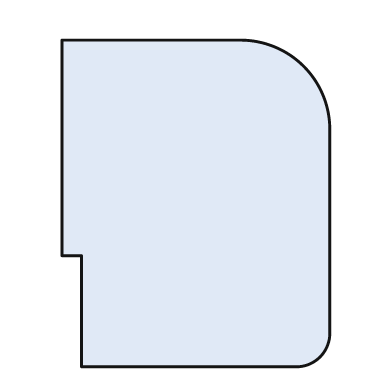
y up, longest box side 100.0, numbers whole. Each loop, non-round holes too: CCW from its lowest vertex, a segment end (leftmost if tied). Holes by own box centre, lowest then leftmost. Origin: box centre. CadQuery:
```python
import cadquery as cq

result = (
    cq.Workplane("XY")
    .moveTo(-35.0, -50.0)
    .lineTo(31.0, -50.0)
    .threePointArc((38.0, -47.0), (41.0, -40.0))
    .lineTo(41.0, 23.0)
    .threePointArc((33.0, 42.0), (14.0, 50.0))
    .lineTo(-41.0, 50.0)
    .lineTo(-41.0, -16.0)
    .lineTo(-35.0, -16.0)
    .close()
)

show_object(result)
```